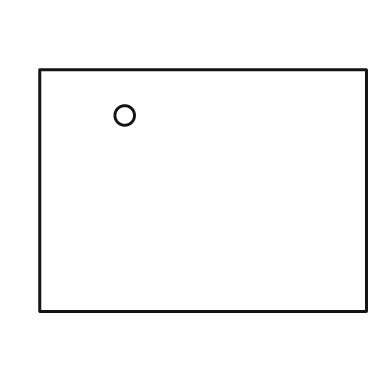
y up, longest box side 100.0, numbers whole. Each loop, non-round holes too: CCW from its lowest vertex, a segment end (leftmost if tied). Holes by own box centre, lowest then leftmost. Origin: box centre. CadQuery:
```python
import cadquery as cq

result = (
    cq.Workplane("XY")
    .moveTo(-50.0, -37.0)
    .lineTo(50.0, -37.0)
    .lineTo(50.0, 37.0)
    .lineTo(-50.0, 37.0)
    .close()
    .moveTo(-24.0, 23.0)
    .circle(3.0)
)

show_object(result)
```